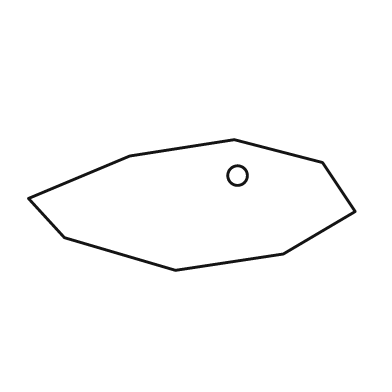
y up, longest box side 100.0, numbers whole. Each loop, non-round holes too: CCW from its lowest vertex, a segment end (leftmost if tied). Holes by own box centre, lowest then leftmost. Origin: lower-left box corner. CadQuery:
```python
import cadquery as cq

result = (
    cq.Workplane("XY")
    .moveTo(45.0, 0.0)
    .lineTo(78.0, 5.0)
    .lineTo(100.0, 18.0)
    .lineTo(90.0, 33.0)
    .lineTo(63.0, 40.0)
    .lineTo(31.0, 35.0)
    .lineTo(0.0, 22.0)
    .lineTo(11.0, 10.0)
    .close()
    .moveTo(64.0, 29.0)
    .circle(3.0)
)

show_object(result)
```